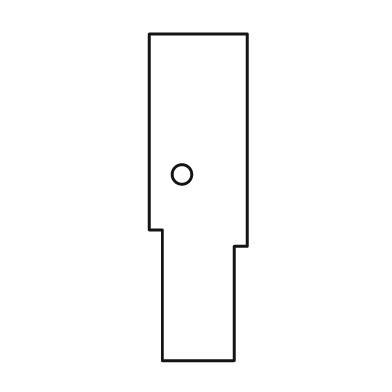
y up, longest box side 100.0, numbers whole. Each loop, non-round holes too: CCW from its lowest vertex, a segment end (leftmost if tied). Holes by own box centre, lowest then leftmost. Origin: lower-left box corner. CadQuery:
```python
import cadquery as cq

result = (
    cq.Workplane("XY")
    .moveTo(4.0, 0.0)
    .lineTo(26.0, 0.0)
    .lineTo(26.0, 35.0)
    .lineTo(30.0, 35.0)
    .lineTo(30.0, 100.0)
    .lineTo(0.0, 100.0)
    .lineTo(0.0, 40.0)
    .lineTo(4.0, 40.0)
    .close()
    .moveTo(10.0, 57.0)
    .circle(3.0)
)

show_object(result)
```